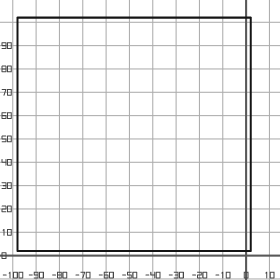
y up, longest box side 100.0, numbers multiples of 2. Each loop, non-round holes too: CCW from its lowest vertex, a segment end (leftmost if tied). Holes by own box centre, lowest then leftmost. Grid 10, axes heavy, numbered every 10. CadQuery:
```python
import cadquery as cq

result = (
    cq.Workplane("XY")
    .moveTo(-98.0, 2.0)
    .lineTo(2.0, 2.0)
    .lineTo(2.0, 102.0)
    .lineTo(-98.0, 102.0)
    .close()
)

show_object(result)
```